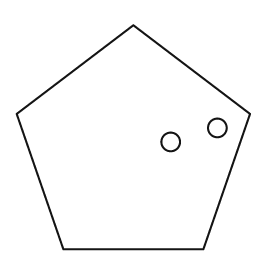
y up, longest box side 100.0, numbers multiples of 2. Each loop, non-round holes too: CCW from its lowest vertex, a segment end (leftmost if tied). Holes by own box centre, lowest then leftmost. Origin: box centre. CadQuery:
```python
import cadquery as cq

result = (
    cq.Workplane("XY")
    .moveTo(-30.0, -48.0)
    .lineTo(30.0, -48.0)
    .lineTo(50.0, 10.0)
    .lineTo(0.0, 48.0)
    .lineTo(-50.0, 10.0)
    .close()
    .moveTo(16.0, -2.0)
    .circle(4.0)
    .moveTo(36.0, 4.0)
    .circle(4.0)
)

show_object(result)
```